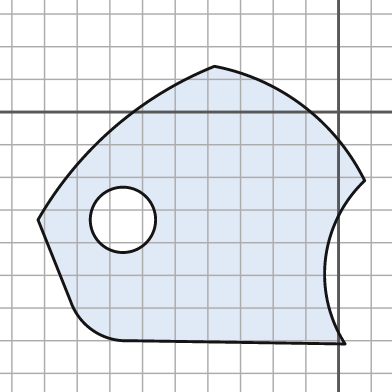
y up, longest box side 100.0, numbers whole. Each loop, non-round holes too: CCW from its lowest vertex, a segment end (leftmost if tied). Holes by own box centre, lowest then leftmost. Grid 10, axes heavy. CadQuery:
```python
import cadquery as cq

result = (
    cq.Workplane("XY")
    .moveTo(2.0, -71.0)
    .threePointArc((-4.0, -45.0), (8.0, -21.0))
    .threePointArc((-11.0, 2.0), (-38.0, 14.0))
    .threePointArc((-69.0, -5.0), (-92.0, -33.0))
    .lineTo(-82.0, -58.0)
    .threePointArc((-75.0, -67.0), (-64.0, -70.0))
    .close()
    .moveTo(-66.0, -33.0)
    .circle(10.0)
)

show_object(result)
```